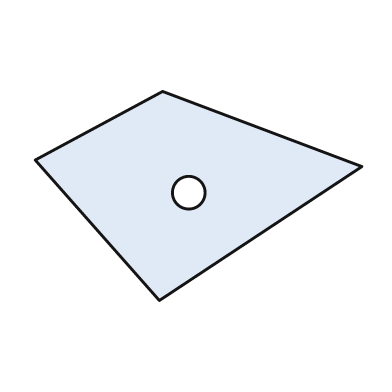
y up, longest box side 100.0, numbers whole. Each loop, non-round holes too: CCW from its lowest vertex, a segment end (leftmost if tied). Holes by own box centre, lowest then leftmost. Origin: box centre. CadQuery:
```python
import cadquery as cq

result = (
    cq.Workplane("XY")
    .moveTo(-12.0, -32.0)
    .lineTo(50.0, 9.0)
    .lineTo(-11.0, 32.0)
    .lineTo(-50.0, 11.0)
    .close()
    .moveTo(-3.0, 1.0)
    .circle(5.0)
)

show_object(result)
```